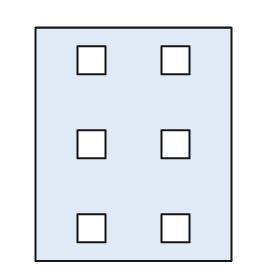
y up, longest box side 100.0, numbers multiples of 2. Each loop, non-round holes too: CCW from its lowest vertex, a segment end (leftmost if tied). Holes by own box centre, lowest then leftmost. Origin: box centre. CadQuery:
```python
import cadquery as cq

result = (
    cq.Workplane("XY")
    .moveTo(-42.0, -50.0)
    .lineTo(42.0, -50.0)
    .lineTo(42.0, 50.0)
    .lineTo(-42.0, 50.0)
    .close()
    .moveTo(-24.0, -42.0)
    .lineTo(-12.0, -42.0)
    .lineTo(-12.0, -30.0)
    .lineTo(-24.0, -30.0)
    .close()
    .moveTo(12.0, -42.0)
    .lineTo(24.0, -42.0)
    .lineTo(24.0, -30.0)
    .lineTo(12.0, -30.0)
    .close()
    .moveTo(-24.0, -6.0)
    .lineTo(-12.0, -6.0)
    .lineTo(-12.0, 6.0)
    .lineTo(-24.0, 6.0)
    .close()
    .moveTo(12.0, -6.0)
    .lineTo(24.0, -6.0)
    .lineTo(24.0, 6.0)
    .lineTo(12.0, 6.0)
    .close()
    .moveTo(-24.0, 30.0)
    .lineTo(-12.0, 30.0)
    .lineTo(-12.0, 42.0)
    .lineTo(-24.0, 42.0)
    .close()
    .moveTo(12.0, 30.0)
    .lineTo(24.0, 30.0)
    .lineTo(24.0, 42.0)
    .lineTo(12.0, 42.0)
    .close()
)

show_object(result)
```